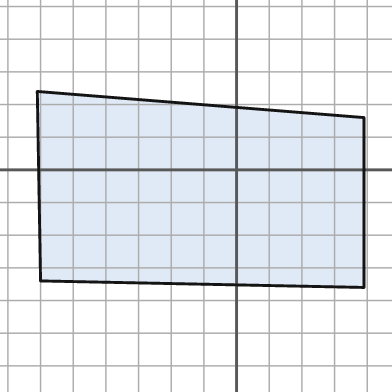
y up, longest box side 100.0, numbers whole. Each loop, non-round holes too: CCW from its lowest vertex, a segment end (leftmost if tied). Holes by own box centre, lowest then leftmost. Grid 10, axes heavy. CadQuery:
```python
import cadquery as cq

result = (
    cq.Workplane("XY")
    .moveTo(39.0, -36.0)
    .lineTo(39.0, 16.0)
    .lineTo(-61.0, 24.0)
    .lineTo(-60.0, -34.0)
    .close()
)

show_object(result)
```